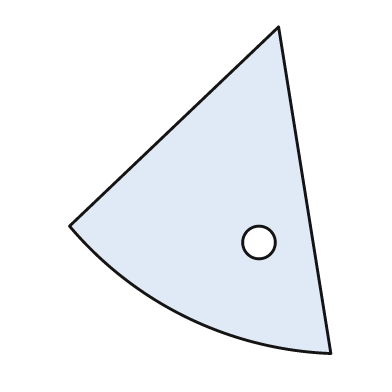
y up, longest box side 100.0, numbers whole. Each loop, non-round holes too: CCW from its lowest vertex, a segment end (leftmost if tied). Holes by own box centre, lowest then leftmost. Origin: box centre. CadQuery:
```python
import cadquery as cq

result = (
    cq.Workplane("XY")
    .moveTo(40.0, -50.0)
    .lineTo(24.0, 50.0)
    .lineTo(-40.0, -11.0)
    .threePointArc((-4.0, -39.0), (40.0, -50.0))
    .close()
    .moveTo(18.0, -16.0)
    .circle(5.0)
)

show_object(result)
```